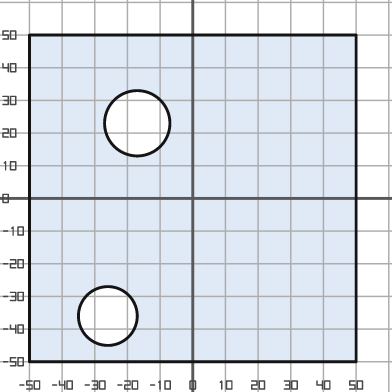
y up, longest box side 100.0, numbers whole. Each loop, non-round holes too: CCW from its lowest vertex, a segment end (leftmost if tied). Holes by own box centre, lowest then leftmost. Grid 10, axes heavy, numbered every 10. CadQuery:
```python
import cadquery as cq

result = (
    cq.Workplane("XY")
    .moveTo(-50.0, -50.0)
    .lineTo(50.0, -50.0)
    .lineTo(50.0, 50.0)
    .lineTo(-50.0, 50.0)
    .close()
    .moveTo(-26.0, -36.0)
    .circle(9.0)
    .moveTo(-17.0, 23.0)
    .circle(10.0)
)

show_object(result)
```